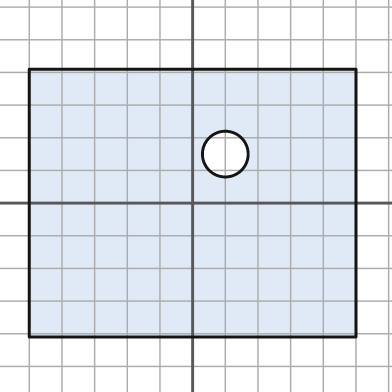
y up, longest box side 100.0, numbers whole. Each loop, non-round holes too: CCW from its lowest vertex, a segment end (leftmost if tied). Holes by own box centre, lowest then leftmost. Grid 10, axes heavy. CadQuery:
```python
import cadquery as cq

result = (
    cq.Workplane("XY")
    .moveTo(-50.0, -41.0)
    .lineTo(50.0, -41.0)
    .lineTo(50.0, 41.0)
    .lineTo(-50.0, 41.0)
    .close()
    .moveTo(10.0, 15.0)
    .circle(7.0)
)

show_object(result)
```